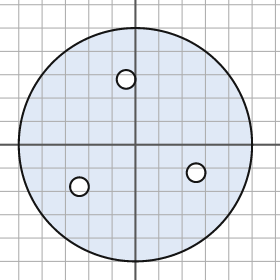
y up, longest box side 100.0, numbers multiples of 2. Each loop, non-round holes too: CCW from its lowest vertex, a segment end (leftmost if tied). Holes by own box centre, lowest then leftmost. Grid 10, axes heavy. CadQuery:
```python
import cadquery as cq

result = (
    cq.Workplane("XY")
    .moveTo(0.0, 0.0)
    .circle(50.0)
    .moveTo(-24.0, -18.0)
    .circle(4.0)
    .moveTo(26.0, -12.0)
    .circle(4.0)
    .moveTo(-4.0, 28.0)
    .circle(4.0)
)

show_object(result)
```